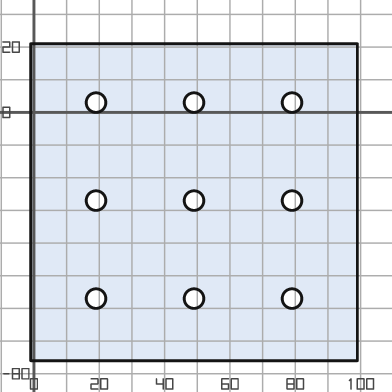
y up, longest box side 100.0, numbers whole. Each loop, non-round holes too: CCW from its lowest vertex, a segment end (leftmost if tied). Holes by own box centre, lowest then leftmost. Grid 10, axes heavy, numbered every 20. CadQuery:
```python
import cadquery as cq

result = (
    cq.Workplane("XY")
    .moveTo(-1.0, -76.0)
    .lineTo(99.0, -76.0)
    .lineTo(99.0, 21.0)
    .lineTo(-1.0, 21.0)
    .close()
    .moveTo(19.0, -57.0)
    .circle(3.0)
    .moveTo(49.0, -57.0)
    .circle(3.0)
    .moveTo(79.0, -57.0)
    .circle(3.0)
    .moveTo(19.0, -27.0)
    .circle(3.0)
    .moveTo(49.0, -27.0)
    .circle(3.0)
    .moveTo(79.0, -27.0)
    .circle(3.0)
    .moveTo(19.0, 3.0)
    .circle(3.0)
    .moveTo(49.0, 3.0)
    .circle(3.0)
    .moveTo(79.0, 3.0)
    .circle(3.0)
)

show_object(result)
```